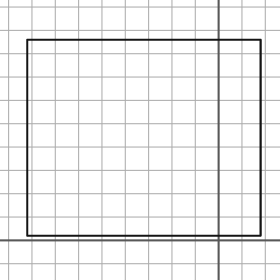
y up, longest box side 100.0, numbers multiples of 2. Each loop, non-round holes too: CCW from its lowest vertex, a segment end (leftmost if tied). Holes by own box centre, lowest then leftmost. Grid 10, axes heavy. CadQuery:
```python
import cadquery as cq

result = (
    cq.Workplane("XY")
    .moveTo(-82.0, 2.0)
    .lineTo(18.0, 2.0)
    .lineTo(18.0, 86.0)
    .lineTo(-82.0, 86.0)
    .close()
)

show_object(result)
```